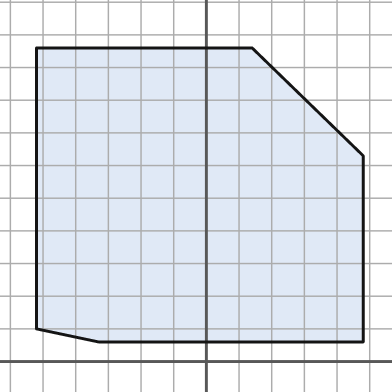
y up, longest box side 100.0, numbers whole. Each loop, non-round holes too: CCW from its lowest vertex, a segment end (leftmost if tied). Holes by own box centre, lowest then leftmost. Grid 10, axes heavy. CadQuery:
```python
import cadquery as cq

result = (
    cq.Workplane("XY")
    .moveTo(-33.0, 6.0)
    .lineTo(48.0, 6.0)
    .lineTo(48.0, 63.0)
    .lineTo(14.0, 96.0)
    .lineTo(-52.0, 96.0)
    .lineTo(-52.0, 10.0)
    .close()
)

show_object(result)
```